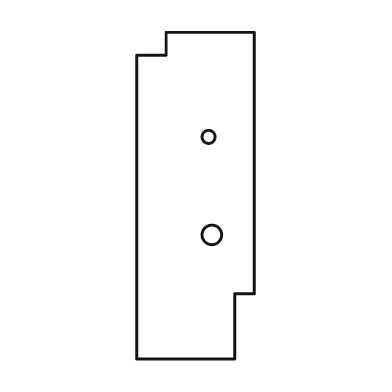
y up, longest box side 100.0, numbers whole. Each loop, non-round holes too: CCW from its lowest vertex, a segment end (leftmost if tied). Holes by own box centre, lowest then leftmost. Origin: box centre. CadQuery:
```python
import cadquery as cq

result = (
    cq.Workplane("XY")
    .moveTo(-18.0, -50.0)
    .lineTo(12.0, -50.0)
    .lineTo(12.0, -30.0)
    .lineTo(18.0, -30.0)
    .lineTo(18.0, 50.0)
    .lineTo(-9.0, 50.0)
    .lineTo(-9.0, 43.0)
    .lineTo(-18.0, 43.0)
    .close()
    .moveTo(5.0, -12.0)
    .circle(3.0)
    .moveTo(4.0, 18.0)
    .circle(2.0)
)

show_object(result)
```